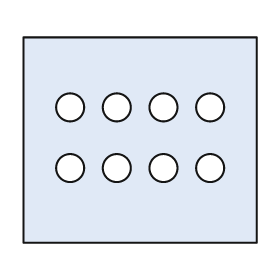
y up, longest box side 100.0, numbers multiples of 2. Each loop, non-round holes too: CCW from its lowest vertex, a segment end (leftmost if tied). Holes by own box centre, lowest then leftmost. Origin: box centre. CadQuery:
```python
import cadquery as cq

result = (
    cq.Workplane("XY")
    .moveTo(-50.0, -44.0)
    .lineTo(50.0, -44.0)
    .lineTo(50.0, 44.0)
    .lineTo(-50.0, 44.0)
    .close()
    .moveTo(-30.0, -12.0)
    .circle(6.0)
    .moveTo(-10.0, -12.0)
    .circle(6.0)
    .moveTo(10.0, -12.0)
    .circle(6.0)
    .moveTo(30.0, -12.0)
    .circle(6.0)
    .moveTo(-30.0, 14.0)
    .circle(6.0)
    .moveTo(-10.0, 14.0)
    .circle(6.0)
    .moveTo(10.0, 14.0)
    .circle(6.0)
    .moveTo(30.0, 14.0)
    .circle(6.0)
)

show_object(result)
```